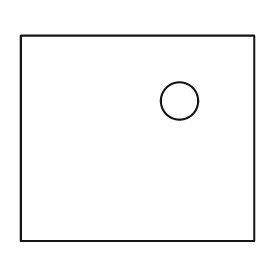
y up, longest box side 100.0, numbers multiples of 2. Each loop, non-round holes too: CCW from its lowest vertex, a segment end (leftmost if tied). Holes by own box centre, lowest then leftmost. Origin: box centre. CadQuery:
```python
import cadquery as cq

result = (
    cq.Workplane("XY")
    .moveTo(-50.0, -44.0)
    .lineTo(50.0, -44.0)
    .lineTo(50.0, 44.0)
    .lineTo(-50.0, 44.0)
    .close()
    .moveTo(18.0, 16.0)
    .circle(8.0)
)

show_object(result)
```